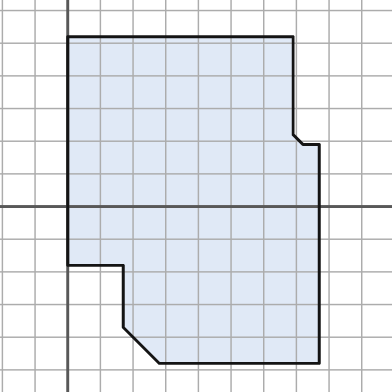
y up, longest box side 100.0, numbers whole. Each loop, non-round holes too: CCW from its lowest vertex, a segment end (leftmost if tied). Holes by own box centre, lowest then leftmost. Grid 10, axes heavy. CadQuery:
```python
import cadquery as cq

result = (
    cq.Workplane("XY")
    .moveTo(28.0, -48.0)
    .lineTo(77.0, -48.0)
    .lineTo(77.0, 19.0)
    .lineTo(72.0, 19.0)
    .lineTo(69.0, 22.0)
    .lineTo(69.0, 52.0)
    .lineTo(0.0, 52.0)
    .lineTo(0.0, -18.0)
    .lineTo(17.0, -18.0)
    .lineTo(17.0, -37.0)
    .close()
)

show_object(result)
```